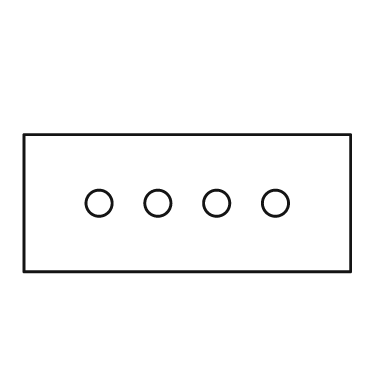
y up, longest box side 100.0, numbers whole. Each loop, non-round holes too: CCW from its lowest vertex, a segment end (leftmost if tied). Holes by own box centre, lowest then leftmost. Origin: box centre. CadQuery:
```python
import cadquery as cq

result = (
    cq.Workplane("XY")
    .moveTo(-50.0, -21.0)
    .lineTo(50.0, -21.0)
    .lineTo(50.0, 21.0)
    .lineTo(-50.0, 21.0)
    .close()
    .moveTo(-27.0, 0.0)
    .circle(4.0)
    .moveTo(-9.0, 0.0)
    .circle(4.0)
    .moveTo(9.0, 0.0)
    .circle(4.0)
    .moveTo(27.0, 0.0)
    .circle(4.0)
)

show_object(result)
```